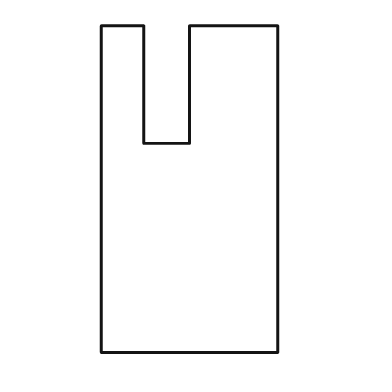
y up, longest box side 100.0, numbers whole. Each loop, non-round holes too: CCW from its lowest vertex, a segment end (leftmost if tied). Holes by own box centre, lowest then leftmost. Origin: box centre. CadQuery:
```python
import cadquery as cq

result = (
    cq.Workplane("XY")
    .moveTo(-27.0, -50.0)
    .lineTo(27.0, -50.0)
    .lineTo(27.0, 50.0)
    .lineTo(0.0, 50.0)
    .lineTo(0.0, 14.0)
    .lineTo(-14.0, 14.0)
    .lineTo(-14.0, 50.0)
    .lineTo(-27.0, 50.0)
    .close()
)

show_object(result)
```